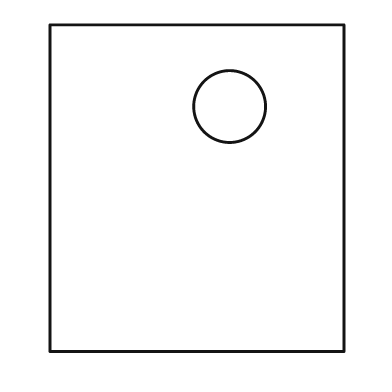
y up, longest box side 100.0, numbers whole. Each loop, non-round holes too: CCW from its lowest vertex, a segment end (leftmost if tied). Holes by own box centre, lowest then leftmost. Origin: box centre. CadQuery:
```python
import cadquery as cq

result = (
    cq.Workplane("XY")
    .moveTo(-45.0, -50.0)
    .lineTo(45.0, -50.0)
    .lineTo(45.0, 50.0)
    .lineTo(-45.0, 50.0)
    .close()
    .moveTo(10.0, 25.0)
    .circle(11.0)
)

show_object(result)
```